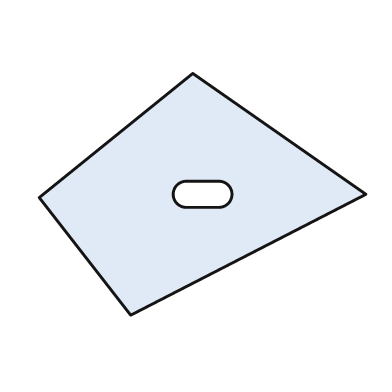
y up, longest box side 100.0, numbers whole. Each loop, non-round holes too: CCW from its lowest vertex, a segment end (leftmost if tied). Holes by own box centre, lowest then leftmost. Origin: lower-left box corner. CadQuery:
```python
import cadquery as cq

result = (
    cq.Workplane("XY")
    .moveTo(28.0, 0.0)
    .lineTo(100.0, 37.0)
    .lineTo(47.0, 74.0)
    .lineTo(0.0, 36.0)
    .close()
    .moveTo(45.0, 33.0)
    .lineTo(55.0, 33.0)
    .threePointArc((59.0, 37.0), (55.0, 41.0))
    .lineTo(45.0, 41.0)
    .threePointArc((41.0, 37.0), (45.0, 33.0))
    .close()
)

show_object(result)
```